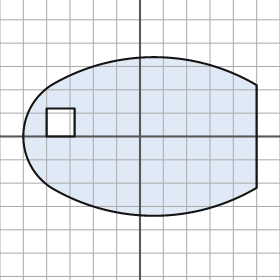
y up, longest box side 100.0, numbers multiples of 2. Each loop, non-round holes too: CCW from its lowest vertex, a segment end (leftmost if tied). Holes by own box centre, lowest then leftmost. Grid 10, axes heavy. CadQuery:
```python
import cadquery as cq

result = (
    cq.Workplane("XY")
    .moveTo(-38.0, -22.0)
    .threePointArc((6.0, -34.0), (50.0, -22.0))
    .lineTo(50.0, 22.0)
    .threePointArc((6.0, 34.0), (-38.0, 22.0))
    .threePointArc((-50.0, 0.0), (-38.0, -22.0))
    .close()
    .moveTo(-40.0, 0.0)
    .lineTo(-28.0, 0.0)
    .lineTo(-28.0, 12.0)
    .lineTo(-40.0, 12.0)
    .close()
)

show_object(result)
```